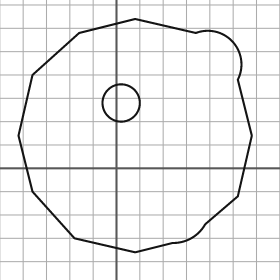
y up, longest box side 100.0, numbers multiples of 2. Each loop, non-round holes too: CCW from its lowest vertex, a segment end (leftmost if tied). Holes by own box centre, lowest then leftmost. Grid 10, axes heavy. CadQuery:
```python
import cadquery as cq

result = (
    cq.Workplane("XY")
    .moveTo(8.0, -36.0)
    .lineTo(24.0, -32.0)
    .threePointArc((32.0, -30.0), (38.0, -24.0))
    .lineTo(52.0, -12.0)
    .lineTo(58.0, 14.0)
    .lineTo(52.0, 38.0)
    .threePointArc((50.0, 54.0), (34.0, 58.0))
    .lineTo(8.0, 64.0)
    .lineTo(-16.0, 58.0)
    .lineTo(-36.0, 40.0)
    .lineTo(-42.0, 14.0)
    .lineTo(-36.0, -10.0)
    .lineTo(-18.0, -30.0)
    .close()
    .moveTo(2.0, 28.0)
    .circle(8.0)
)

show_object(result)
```